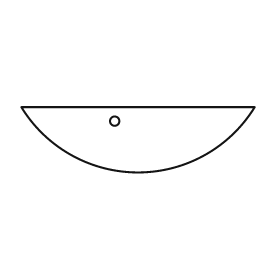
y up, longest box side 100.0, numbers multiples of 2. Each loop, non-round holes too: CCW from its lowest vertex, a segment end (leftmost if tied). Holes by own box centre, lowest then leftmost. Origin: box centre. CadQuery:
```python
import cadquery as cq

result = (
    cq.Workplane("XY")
    .moveTo(-50.0, 14.0)
    .threePointArc((0.0, -14.0), (50.0, 14.0))
    .close()
    .moveTo(-10.0, 8.0)
    .circle(2.0)
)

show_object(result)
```